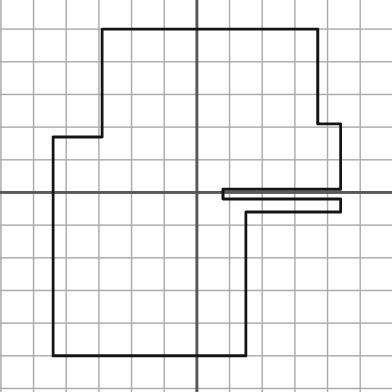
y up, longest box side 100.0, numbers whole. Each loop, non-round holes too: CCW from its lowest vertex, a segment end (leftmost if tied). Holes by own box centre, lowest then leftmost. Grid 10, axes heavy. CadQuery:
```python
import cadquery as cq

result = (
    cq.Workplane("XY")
    .moveTo(-44.0, -50.0)
    .lineTo(15.0, -50.0)
    .lineTo(15.0, -6.0)
    .lineTo(44.0, -6.0)
    .lineTo(44.0, -2.0)
    .lineTo(8.0, -2.0)
    .lineTo(8.0, 1.0)
    .lineTo(44.0, 1.0)
    .lineTo(44.0, 21.0)
    .lineTo(37.0, 21.0)
    .lineTo(37.0, 50.0)
    .lineTo(-29.0, 50.0)
    .lineTo(-29.0, 17.0)
    .lineTo(-44.0, 17.0)
    .close()
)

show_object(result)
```